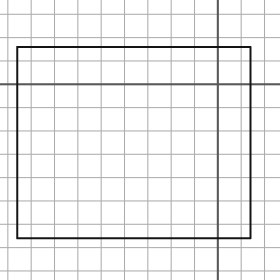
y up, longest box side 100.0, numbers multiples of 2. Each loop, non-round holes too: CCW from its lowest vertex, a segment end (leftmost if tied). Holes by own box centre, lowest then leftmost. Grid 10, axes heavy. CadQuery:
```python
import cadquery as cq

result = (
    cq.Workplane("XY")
    .moveTo(-86.0, -66.0)
    .lineTo(14.0, -66.0)
    .lineTo(14.0, 16.0)
    .lineTo(-86.0, 16.0)
    .close()
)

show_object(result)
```